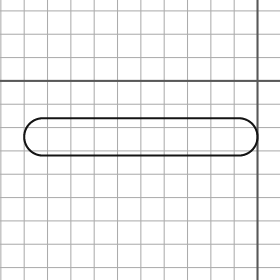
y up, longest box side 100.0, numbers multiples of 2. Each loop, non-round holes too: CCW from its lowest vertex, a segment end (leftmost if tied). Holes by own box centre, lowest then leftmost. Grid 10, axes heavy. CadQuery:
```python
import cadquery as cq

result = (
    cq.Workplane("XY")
    .moveTo(-92.0, -32.0)
    .lineTo(-8.0, -32.0)
    .threePointArc((0.0, -24.0), (-8.0, -16.0))
    .lineTo(-92.0, -16.0)
    .threePointArc((-100.0, -24.0), (-92.0, -32.0))
    .close()
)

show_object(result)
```